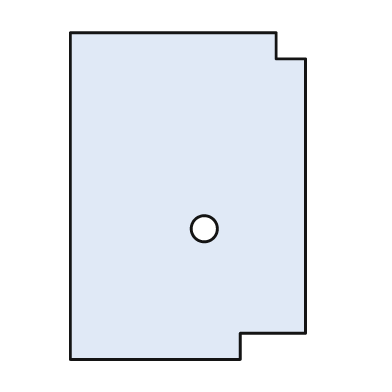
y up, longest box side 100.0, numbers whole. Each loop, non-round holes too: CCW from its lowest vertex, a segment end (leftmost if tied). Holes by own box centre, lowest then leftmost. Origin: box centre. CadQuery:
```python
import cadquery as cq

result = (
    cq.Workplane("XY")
    .moveTo(-36.0, -50.0)
    .lineTo(16.0, -50.0)
    .lineTo(16.0, -42.0)
    .lineTo(36.0, -42.0)
    .lineTo(36.0, 42.0)
    .lineTo(27.0, 42.0)
    .lineTo(27.0, 50.0)
    .lineTo(-36.0, 50.0)
    .close()
    .moveTo(5.0, -10.0)
    .circle(4.0)
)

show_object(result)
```